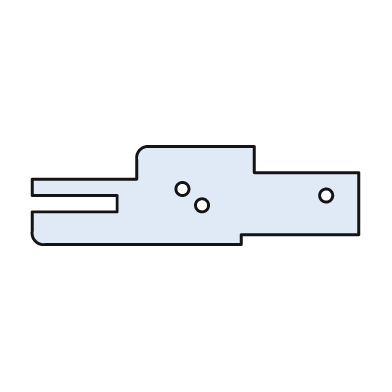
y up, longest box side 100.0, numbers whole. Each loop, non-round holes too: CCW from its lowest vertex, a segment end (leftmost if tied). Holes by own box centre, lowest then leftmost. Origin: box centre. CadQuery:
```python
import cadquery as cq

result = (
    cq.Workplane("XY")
    .moveTo(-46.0, -15.0)
    .lineTo(14.0, -15.0)
    .lineTo(14.0, -12.0)
    .lineTo(50.0, -12.0)
    .lineTo(50.0, 7.0)
    .lineTo(18.0, 7.0)
    .lineTo(18.0, 15.0)
    .lineTo(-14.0, 15.0)
    .threePointArc((-17.0, 14.0), (-18.0, 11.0))
    .lineTo(-18.0, 5.0)
    .lineTo(-50.0, 5.0)
    .lineTo(-50.0, 0.0)
    .lineTo(-24.0, 0.0)
    .lineTo(-24.0, -5.0)
    .lineTo(-50.0, -5.0)
    .lineTo(-50.0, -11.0)
    .threePointArc((-49.0, -14.0), (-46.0, -15.0))
    .close()
    .moveTo(2.0, -3.0)
    .circle(2.0)
    .moveTo(40.0, 0.0)
    .circle(2.0)
    .moveTo(-4.0, 2.0)
    .circle(2.0)
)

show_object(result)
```